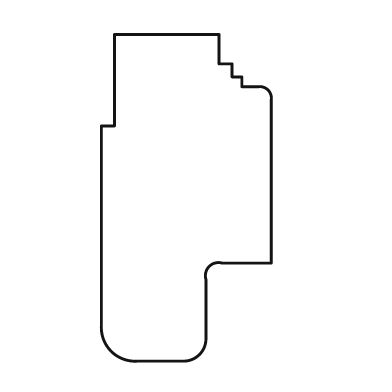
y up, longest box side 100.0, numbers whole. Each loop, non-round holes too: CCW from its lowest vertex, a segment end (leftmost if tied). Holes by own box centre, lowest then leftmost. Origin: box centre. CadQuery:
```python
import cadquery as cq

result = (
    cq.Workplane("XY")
    .moveTo(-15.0, -50.0)
    .lineTo(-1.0, -50.0)
    .threePointArc((4.0, -48.0), (6.0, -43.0))
    .lineTo(6.0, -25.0)
    .threePointArc((7.0, -21.0), (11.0, -20.0))
    .lineTo(26.0, -20.0)
    .lineTo(26.0, 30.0)
    .threePointArc((25.0, 33.0), (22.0, 34.0))
    .lineTo(17.0, 34.0)
    .lineTo(17.0, 37.0)
    .lineTo(14.0, 37.0)
    .lineTo(14.0, 41.0)
    .lineTo(10.0, 41.0)
    .lineTo(10.0, 50.0)
    .lineTo(-22.0, 50.0)
    .lineTo(-22.0, 22.0)
    .lineTo(-26.0, 22.0)
    .lineTo(-26.0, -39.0)
    .threePointArc((-23.0, -47.0), (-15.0, -50.0))
    .close()
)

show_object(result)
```